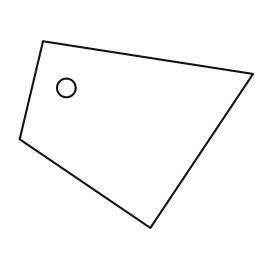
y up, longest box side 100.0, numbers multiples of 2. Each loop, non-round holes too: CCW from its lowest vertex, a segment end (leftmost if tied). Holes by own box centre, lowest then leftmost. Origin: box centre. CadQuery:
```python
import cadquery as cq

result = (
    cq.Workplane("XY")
    .moveTo(6.0, -40.0)
    .lineTo(50.0, 26.0)
    .lineTo(-40.0, 40.0)
    .lineTo(-50.0, -2.0)
    .close()
    .moveTo(-30.0, 20.0)
    .circle(4.0)
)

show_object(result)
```